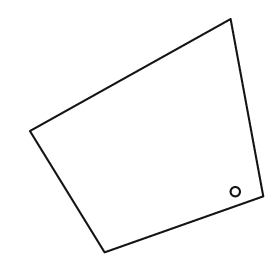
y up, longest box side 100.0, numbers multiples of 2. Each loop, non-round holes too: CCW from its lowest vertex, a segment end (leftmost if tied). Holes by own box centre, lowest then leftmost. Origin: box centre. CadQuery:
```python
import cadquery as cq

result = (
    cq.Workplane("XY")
    .moveTo(-18.0, -50.0)
    .lineTo(50.0, -26.0)
    .lineTo(36.0, 50.0)
    .lineTo(-50.0, 2.0)
    .close()
    .moveTo(38.0, -24.0)
    .circle(2.0)
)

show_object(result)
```